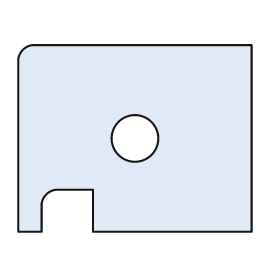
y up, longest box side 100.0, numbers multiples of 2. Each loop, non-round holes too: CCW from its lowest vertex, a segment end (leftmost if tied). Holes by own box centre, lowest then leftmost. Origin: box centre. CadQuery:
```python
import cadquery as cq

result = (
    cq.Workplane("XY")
    .moveTo(-50.0, -40.0)
    .lineTo(-40.0, -40.0)
    .lineTo(-40.0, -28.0)
    .threePointArc((-38.0, -24.0), (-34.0, -22.0))
    .lineTo(-18.0, -22.0)
    .lineTo(-18.0, -40.0)
    .lineTo(50.0, -40.0)
    .lineTo(50.0, 40.0)
    .lineTo(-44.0, 40.0)
    .threePointArc((-48.0, 38.0), (-50.0, 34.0))
    .close()
    .moveTo(0.0, 0.0)
    .circle(10.0)
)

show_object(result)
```